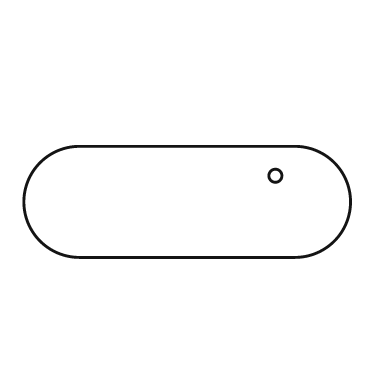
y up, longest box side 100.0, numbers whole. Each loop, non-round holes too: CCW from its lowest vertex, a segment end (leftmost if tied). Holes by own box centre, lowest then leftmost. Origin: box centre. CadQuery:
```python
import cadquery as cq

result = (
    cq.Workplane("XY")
    .moveTo(-33.0, -17.0)
    .lineTo(33.0, -17.0)
    .threePointArc((50.0, 0.0), (33.0, 17.0))
    .lineTo(-33.0, 17.0)
    .threePointArc((-50.0, 0.0), (-33.0, -17.0))
    .close()
    .moveTo(27.0, 8.0)
    .circle(2.0)
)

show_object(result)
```